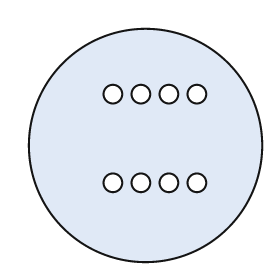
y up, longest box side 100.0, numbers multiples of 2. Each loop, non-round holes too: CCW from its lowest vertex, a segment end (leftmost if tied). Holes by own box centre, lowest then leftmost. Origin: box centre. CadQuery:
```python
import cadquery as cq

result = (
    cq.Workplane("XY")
    .moveTo(0.0, 0.0)
    .circle(50.0)
    .moveTo(-14.0, -16.0)
    .circle(4.0)
    .moveTo(-2.0, -16.0)
    .circle(4.0)
    .moveTo(10.0, -16.0)
    .circle(4.0)
    .moveTo(22.0, -16.0)
    .circle(4.0)
    .moveTo(-14.0, 22.0)
    .circle(4.0)
    .moveTo(-2.0, 22.0)
    .circle(4.0)
    .moveTo(10.0, 22.0)
    .circle(4.0)
    .moveTo(22.0, 22.0)
    .circle(4.0)
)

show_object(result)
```